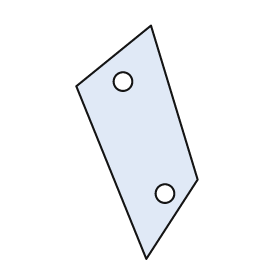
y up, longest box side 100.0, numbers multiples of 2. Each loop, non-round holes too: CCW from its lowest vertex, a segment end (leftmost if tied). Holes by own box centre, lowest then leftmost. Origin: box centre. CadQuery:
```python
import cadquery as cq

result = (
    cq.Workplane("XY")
    .moveTo(4.0, -50.0)
    .lineTo(26.0, -16.0)
    .lineTo(6.0, 50.0)
    .lineTo(-26.0, 24.0)
    .close()
    .moveTo(12.0, -22.0)
    .circle(4.0)
    .moveTo(-6.0, 26.0)
    .circle(4.0)
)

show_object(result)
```